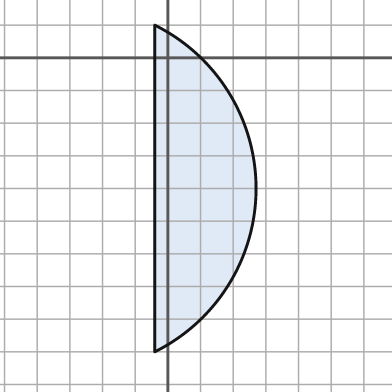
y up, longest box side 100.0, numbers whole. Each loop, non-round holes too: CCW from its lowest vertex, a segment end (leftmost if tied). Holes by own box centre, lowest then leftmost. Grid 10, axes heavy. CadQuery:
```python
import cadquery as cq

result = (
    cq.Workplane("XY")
    .moveTo(-4.0, -90.0)
    .threePointArc((27.0, -40.0), (-4.0, 10.0))
    .close()
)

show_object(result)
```